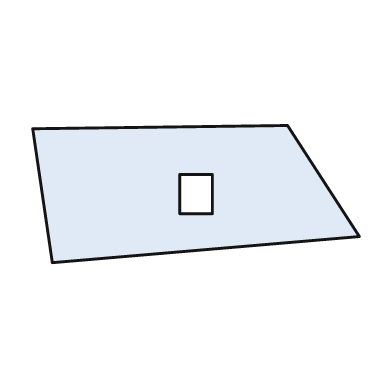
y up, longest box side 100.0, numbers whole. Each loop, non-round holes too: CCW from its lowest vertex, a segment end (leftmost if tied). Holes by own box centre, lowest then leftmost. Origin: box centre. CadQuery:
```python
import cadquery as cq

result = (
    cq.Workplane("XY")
    .moveTo(-44.0, -21.0)
    .lineTo(50.0, -13.0)
    .lineTo(28.0, 21.0)
    .lineTo(-50.0, 20.0)
    .close()
    .moveTo(-5.0, -6.0)
    .lineTo(5.0, -6.0)
    .lineTo(5.0, 6.0)
    .lineTo(-5.0, 6.0)
    .close()
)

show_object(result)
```